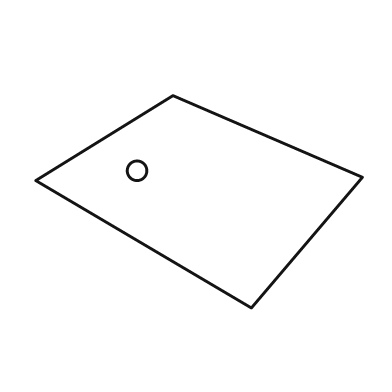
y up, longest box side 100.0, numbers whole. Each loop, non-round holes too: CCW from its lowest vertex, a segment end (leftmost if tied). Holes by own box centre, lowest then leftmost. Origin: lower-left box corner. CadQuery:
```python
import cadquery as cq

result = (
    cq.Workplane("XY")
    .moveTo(66.0, 0.0)
    .lineTo(100.0, 40.0)
    .lineTo(42.0, 65.0)
    .lineTo(0.0, 39.0)
    .close()
    .moveTo(31.0, 42.0)
    .circle(3.0)
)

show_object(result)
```